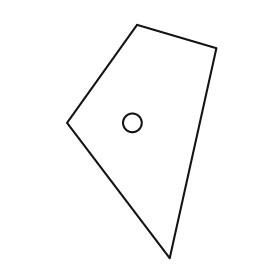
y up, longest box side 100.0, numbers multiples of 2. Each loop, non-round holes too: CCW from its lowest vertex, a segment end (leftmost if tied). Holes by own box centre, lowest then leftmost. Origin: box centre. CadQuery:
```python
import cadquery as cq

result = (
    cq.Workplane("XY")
    .moveTo(12.0, -50.0)
    .lineTo(32.0, 40.0)
    .lineTo(-2.0, 50.0)
    .lineTo(-32.0, 8.0)
    .close()
    .moveTo(-4.0, 8.0)
    .circle(4.0)
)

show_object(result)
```